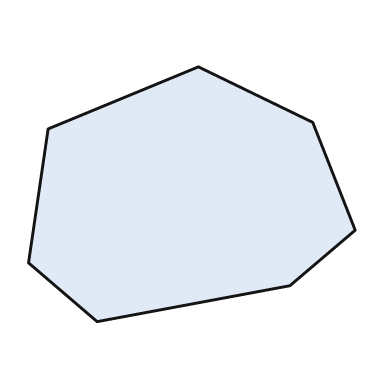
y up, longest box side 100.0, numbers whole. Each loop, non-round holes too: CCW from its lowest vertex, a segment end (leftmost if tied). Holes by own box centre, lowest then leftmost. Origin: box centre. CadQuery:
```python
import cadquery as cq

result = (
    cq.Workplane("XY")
    .moveTo(-29.0, -39.0)
    .lineTo(30.0, -28.0)
    .lineTo(50.0, -11.0)
    .lineTo(37.0, 22.0)
    .lineTo(2.0, 39.0)
    .lineTo(-44.0, 20.0)
    .lineTo(-50.0, -21.0)
    .close()
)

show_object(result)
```